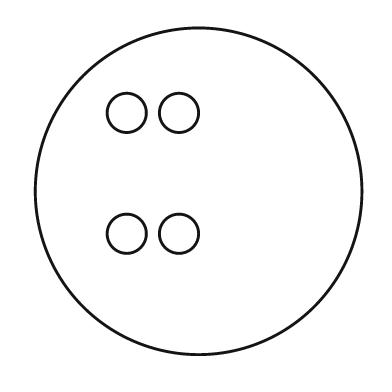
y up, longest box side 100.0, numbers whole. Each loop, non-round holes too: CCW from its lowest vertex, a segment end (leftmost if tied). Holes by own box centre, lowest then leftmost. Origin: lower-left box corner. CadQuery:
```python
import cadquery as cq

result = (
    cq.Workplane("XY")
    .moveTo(50.0, 50.0)
    .circle(50.0)
    .moveTo(28.0, 37.0)
    .circle(6.0)
    .moveTo(44.0, 37.0)
    .circle(6.0)
    .moveTo(28.0, 74.0)
    .circle(6.0)
    .moveTo(44.0, 74.0)
    .circle(6.0)
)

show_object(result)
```